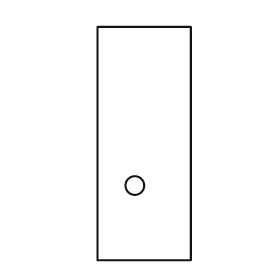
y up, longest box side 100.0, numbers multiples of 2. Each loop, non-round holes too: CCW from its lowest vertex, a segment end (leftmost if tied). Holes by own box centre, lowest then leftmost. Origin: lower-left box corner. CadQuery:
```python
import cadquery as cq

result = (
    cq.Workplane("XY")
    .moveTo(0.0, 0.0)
    .lineTo(40.0, 0.0)
    .lineTo(40.0, 100.0)
    .lineTo(0.0, 100.0)
    .close()
    .moveTo(16.0, 32.0)
    .circle(4.0)
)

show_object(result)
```